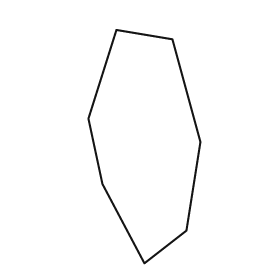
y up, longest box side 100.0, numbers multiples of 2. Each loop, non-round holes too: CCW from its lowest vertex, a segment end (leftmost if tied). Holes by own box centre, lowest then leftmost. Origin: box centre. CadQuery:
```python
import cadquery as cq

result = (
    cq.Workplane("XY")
    .moveTo(0.0, -50.0)
    .lineTo(18.0, -36.0)
    .lineTo(24.0, 2.0)
    .lineTo(12.0, 46.0)
    .lineTo(-12.0, 50.0)
    .lineTo(-24.0, 12.0)
    .lineTo(-18.0, -16.0)
    .close()
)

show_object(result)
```